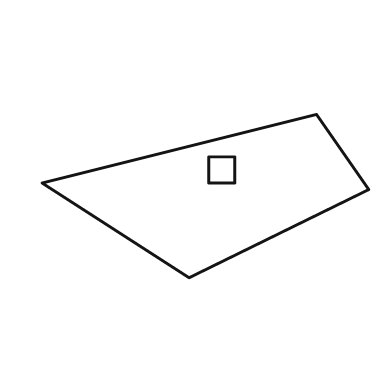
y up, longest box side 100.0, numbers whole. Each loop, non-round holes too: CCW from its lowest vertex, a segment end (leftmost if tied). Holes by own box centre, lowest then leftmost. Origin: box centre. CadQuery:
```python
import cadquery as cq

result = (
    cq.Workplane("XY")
    .moveTo(-5.0, -25.0)
    .lineTo(50.0, 2.0)
    .lineTo(34.0, 25.0)
    .lineTo(-50.0, 4.0)
    .close()
    .moveTo(1.0, 4.0)
    .lineTo(9.0, 4.0)
    .lineTo(9.0, 12.0)
    .lineTo(1.0, 12.0)
    .close()
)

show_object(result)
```